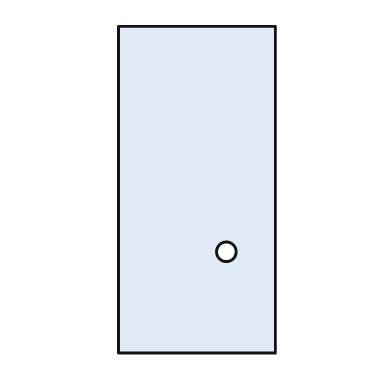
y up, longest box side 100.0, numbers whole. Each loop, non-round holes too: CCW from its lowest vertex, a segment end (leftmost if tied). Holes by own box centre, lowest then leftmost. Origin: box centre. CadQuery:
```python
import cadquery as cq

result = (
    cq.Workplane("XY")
    .moveTo(-24.0, -50.0)
    .lineTo(24.0, -50.0)
    .lineTo(24.0, 50.0)
    .lineTo(-24.0, 50.0)
    .close()
    .moveTo(9.0, -19.0)
    .circle(3.0)
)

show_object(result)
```